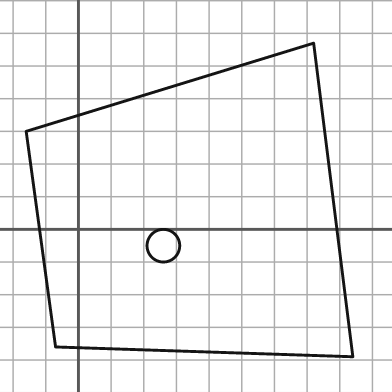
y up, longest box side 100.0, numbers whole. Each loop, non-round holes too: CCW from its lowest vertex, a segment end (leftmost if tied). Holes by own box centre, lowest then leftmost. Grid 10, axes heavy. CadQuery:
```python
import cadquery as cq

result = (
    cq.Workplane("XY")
    .moveTo(84.0, -39.0)
    .lineTo(72.0, 57.0)
    .lineTo(-16.0, 30.0)
    .lineTo(-7.0, -36.0)
    .close()
    .moveTo(26.0, -5.0)
    .circle(5.0)
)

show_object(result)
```